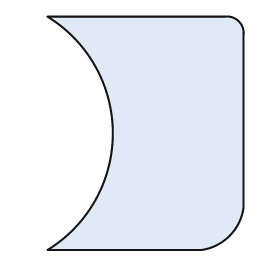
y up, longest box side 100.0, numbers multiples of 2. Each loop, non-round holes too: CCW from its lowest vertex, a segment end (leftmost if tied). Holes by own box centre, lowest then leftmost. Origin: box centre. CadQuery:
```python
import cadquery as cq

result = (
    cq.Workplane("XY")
    .moveTo(-42.0, -50.0)
    .lineTo(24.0, -50.0)
    .threePointArc((36.0, -44.0), (42.0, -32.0))
    .lineTo(42.0, 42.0)
    .threePointArc((40.0, 48.0), (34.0, 50.0))
    .lineTo(-42.0, 50.0)
    .threePointArc((-14.0, 0.0), (-42.0, -50.0))
    .close()
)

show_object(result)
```